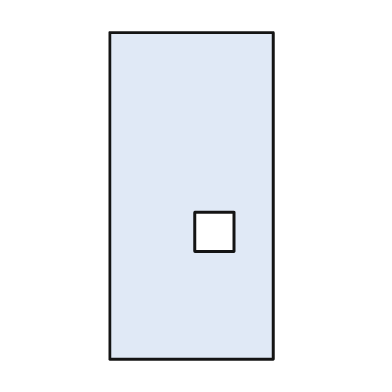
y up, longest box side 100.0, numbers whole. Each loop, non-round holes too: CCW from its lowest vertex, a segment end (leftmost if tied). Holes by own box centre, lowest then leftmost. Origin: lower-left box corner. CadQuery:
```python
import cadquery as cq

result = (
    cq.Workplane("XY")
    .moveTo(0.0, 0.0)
    .lineTo(50.0, 0.0)
    .lineTo(50.0, 100.0)
    .lineTo(0.0, 100.0)
    .close()
    .moveTo(26.0, 33.0)
    .lineTo(38.0, 33.0)
    .lineTo(38.0, 45.0)
    .lineTo(26.0, 45.0)
    .close()
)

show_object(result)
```